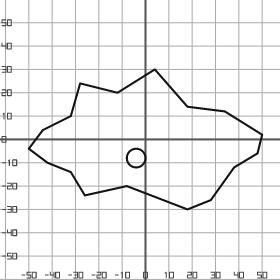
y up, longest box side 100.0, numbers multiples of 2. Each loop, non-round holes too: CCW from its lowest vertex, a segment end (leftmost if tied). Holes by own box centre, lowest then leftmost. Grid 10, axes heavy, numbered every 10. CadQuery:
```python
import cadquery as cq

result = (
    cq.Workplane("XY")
    .moveTo(18.0, -30.0)
    .lineTo(28.0, -26.0)
    .lineTo(38.0, -12.0)
    .lineTo(48.0, -6.0)
    .lineTo(50.0, 2.0)
    .lineTo(34.0, 12.0)
    .lineTo(18.0, 14.0)
    .lineTo(4.0, 30.0)
    .lineTo(-12.0, 20.0)
    .lineTo(-28.0, 24.0)
    .lineTo(-32.0, 10.0)
    .lineTo(-44.0, 4.0)
    .lineTo(-50.0, -4.0)
    .lineTo(-42.0, -10.0)
    .lineTo(-32.0, -14.0)
    .lineTo(-26.0, -24.0)
    .lineTo(-8.0, -20.0)
    .close()
    .moveTo(-4.0, -8.0)
    .circle(4.0)
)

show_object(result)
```